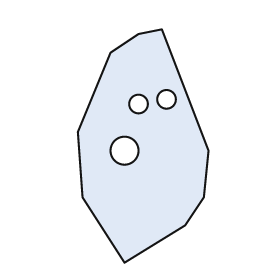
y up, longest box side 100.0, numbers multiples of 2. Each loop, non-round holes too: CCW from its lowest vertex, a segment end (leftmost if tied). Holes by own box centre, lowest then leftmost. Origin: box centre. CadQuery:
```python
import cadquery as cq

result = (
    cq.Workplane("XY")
    .moveTo(-8.0, -50.0)
    .lineTo(18.0, -34.0)
    .lineTo(26.0, -22.0)
    .lineTo(28.0, -2.0)
    .lineTo(8.0, 50.0)
    .lineTo(-2.0, 48.0)
    .lineTo(-14.0, 40.0)
    .lineTo(-28.0, 6.0)
    .lineTo(-26.0, -22.0)
    .close()
    .moveTo(-8.0, -2.0)
    .circle(6.0)
    .moveTo(-2.0, 18.0)
    .circle(4.0)
    .moveTo(10.0, 20.0)
    .circle(4.0)
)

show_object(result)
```